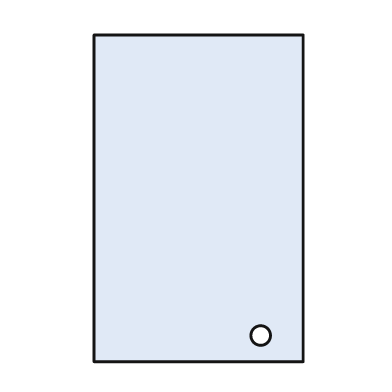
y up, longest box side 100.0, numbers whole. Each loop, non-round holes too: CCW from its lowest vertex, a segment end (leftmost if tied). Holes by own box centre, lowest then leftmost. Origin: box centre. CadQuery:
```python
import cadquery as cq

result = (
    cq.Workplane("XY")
    .moveTo(-32.0, -50.0)
    .lineTo(32.0, -50.0)
    .lineTo(32.0, 50.0)
    .lineTo(-32.0, 50.0)
    .close()
    .moveTo(19.0, -42.0)
    .circle(3.0)
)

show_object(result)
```